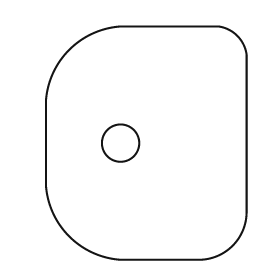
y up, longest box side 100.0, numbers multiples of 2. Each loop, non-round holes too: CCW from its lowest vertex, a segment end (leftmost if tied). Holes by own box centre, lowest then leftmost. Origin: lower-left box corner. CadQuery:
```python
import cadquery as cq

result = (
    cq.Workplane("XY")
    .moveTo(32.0, 0.0)
    .lineTo(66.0, 0.0)
    .threePointArc((80.0, 6.0), (86.0, 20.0))
    .lineTo(86.0, 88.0)
    .threePointArc((82.0, 96.0), (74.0, 100.0))
    .lineTo(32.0, 100.0)
    .threePointArc((10.0, 90.0), (0.0, 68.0))
    .lineTo(0.0, 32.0)
    .threePointArc((10.0, 10.0), (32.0, 0.0))
    .close()
    .moveTo(32.0, 50.0)
    .circle(8.0)
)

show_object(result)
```